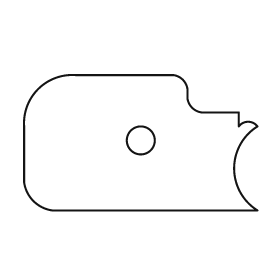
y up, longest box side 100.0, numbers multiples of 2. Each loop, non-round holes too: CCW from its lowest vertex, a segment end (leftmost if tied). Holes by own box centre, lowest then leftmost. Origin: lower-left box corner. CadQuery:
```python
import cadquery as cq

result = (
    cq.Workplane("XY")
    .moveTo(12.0, 0.0)
    .lineTo(100.0, 0.0)
    .threePointArc((90.0, 18.0), (100.0, 36.0))
    .threePointArc((96.0, 38.0), (92.0, 36.0))
    .lineTo(92.0, 42.0)
    .lineTo(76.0, 42.0)
    .threePointArc((72.0, 44.0), (70.0, 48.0))
    .lineTo(70.0, 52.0)
    .threePointArc((68.0, 56.0), (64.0, 58.0))
    .lineTo(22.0, 58.0)
    .threePointArc((6.0, 52.0), (0.0, 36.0))
    .lineTo(0.0, 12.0)
    .threePointArc((4.0, 4.0), (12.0, 0.0))
    .close()
    .moveTo(50.0, 30.0)
    .circle(6.0)
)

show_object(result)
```